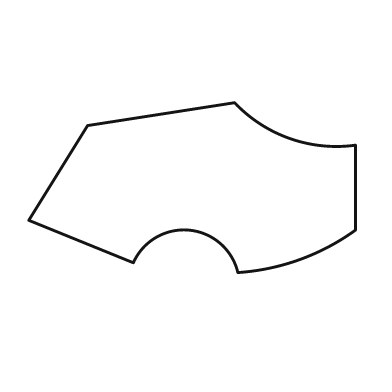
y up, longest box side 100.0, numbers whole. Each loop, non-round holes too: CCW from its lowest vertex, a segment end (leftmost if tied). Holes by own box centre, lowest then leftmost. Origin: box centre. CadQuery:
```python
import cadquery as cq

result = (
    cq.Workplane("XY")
    .moveTo(14.0, -26.0)
    .threePointArc((33.0, -22.0), (50.0, -13.0))
    .lineTo(50.0, 13.0)
    .threePointArc((30.0, 15.0), (13.0, 26.0))
    .lineTo(-32.0, 19.0)
    .lineTo(-50.0, -10.0)
    .lineTo(-18.0, -23.0)
    .threePointArc((-1.0, -13.0), (14.0, -26.0))
    .close()
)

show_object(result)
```